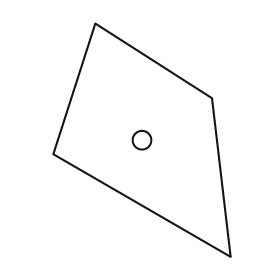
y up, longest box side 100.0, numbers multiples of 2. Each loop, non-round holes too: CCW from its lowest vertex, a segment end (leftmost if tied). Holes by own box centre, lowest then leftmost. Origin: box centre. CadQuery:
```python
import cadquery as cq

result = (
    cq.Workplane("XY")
    .moveTo(38.0, -50.0)
    .lineTo(30.0, 18.0)
    .lineTo(-20.0, 50.0)
    .lineTo(-38.0, -6.0)
    .close()
    .moveTo(0.0, 0.0)
    .circle(4.0)
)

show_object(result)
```